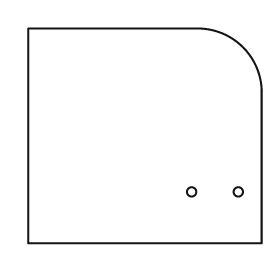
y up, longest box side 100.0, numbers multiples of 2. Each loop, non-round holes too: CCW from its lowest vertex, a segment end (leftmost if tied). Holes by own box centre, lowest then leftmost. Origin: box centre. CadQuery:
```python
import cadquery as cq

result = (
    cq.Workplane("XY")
    .moveTo(-50.0, -46.0)
    .lineTo(50.0, -46.0)
    .lineTo(50.0, 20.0)
    .threePointArc((42.0, 38.0), (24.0, 46.0))
    .lineTo(-50.0, 46.0)
    .close()
    .moveTo(20.0, -24.0)
    .circle(2.0)
    .moveTo(40.0, -24.0)
    .circle(2.0)
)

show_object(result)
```